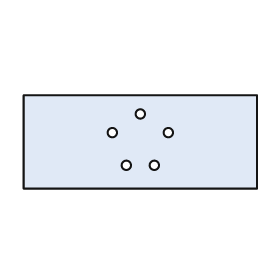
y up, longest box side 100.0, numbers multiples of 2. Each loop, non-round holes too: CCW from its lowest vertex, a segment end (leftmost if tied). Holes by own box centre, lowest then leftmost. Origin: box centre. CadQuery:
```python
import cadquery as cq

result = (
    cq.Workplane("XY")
    .moveTo(-50.0, -20.0)
    .lineTo(50.0, -20.0)
    .lineTo(50.0, 20.0)
    .lineTo(-50.0, 20.0)
    .close()
    .moveTo(-6.0, -10.0)
    .circle(2.0)
    .moveTo(6.0, -10.0)
    .circle(2.0)
    .moveTo(-12.0, 4.0)
    .circle(2.0)
    .moveTo(12.0, 4.0)
    .circle(2.0)
    .moveTo(0.0, 12.0)
    .circle(2.0)
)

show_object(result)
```